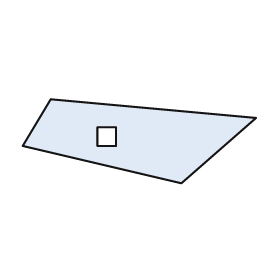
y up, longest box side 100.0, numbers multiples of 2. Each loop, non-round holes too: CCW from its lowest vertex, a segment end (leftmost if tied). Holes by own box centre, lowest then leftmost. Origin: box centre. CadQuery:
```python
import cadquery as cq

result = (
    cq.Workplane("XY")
    .moveTo(18.0, -18.0)
    .lineTo(50.0, 10.0)
    .lineTo(-38.0, 18.0)
    .lineTo(-50.0, -2.0)
    .close()
    .moveTo(-18.0, -2.0)
    .lineTo(-10.0, -2.0)
    .lineTo(-10.0, 6.0)
    .lineTo(-18.0, 6.0)
    .close()
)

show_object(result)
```